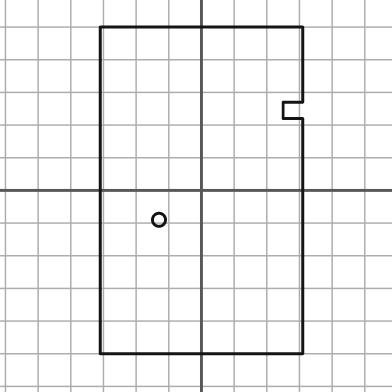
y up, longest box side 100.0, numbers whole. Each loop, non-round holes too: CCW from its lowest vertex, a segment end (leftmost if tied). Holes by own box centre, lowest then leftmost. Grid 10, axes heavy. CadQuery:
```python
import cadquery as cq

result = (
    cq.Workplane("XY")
    .moveTo(-31.0, -50.0)
    .lineTo(31.0, -50.0)
    .lineTo(31.0, 22.0)
    .lineTo(25.0, 22.0)
    .lineTo(25.0, 27.0)
    .lineTo(31.0, 27.0)
    .lineTo(31.0, 50.0)
    .lineTo(-31.0, 50.0)
    .close()
    .moveTo(-13.0, -9.0)
    .circle(2.0)
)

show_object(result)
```